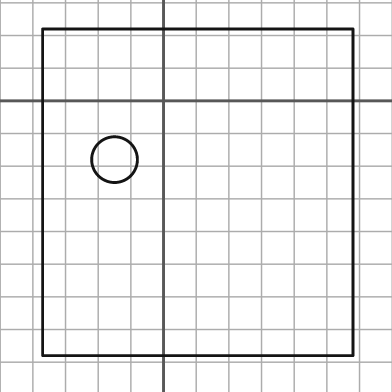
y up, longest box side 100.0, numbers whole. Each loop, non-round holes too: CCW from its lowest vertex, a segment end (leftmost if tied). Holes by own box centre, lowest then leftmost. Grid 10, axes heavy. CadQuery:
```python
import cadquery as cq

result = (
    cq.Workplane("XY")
    .moveTo(-37.0, -78.0)
    .lineTo(58.0, -78.0)
    .lineTo(58.0, 22.0)
    .lineTo(-37.0, 22.0)
    .close()
    .moveTo(-15.0, -18.0)
    .circle(7.0)
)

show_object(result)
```